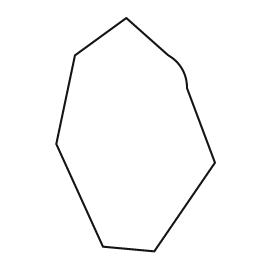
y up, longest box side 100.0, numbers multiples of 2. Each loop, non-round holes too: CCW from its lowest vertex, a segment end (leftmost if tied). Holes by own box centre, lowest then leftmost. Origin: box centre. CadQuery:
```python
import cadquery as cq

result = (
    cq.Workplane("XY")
    .moveTo(8.0, -50.0)
    .lineTo(34.0, -12.0)
    .lineTo(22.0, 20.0)
    .threePointArc((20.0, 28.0), (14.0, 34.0))
    .lineTo(-4.0, 50.0)
    .lineTo(-26.0, 34.0)
    .lineTo(-34.0, -4.0)
    .lineTo(-14.0, -48.0)
    .close()
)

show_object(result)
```